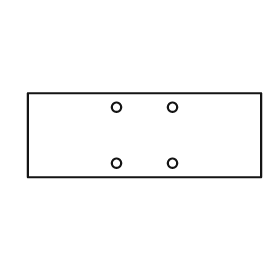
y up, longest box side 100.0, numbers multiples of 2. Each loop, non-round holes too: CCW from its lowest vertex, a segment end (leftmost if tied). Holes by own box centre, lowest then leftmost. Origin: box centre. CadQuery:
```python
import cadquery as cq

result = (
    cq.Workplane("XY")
    .moveTo(-50.0, -18.0)
    .lineTo(50.0, -18.0)
    .lineTo(50.0, 18.0)
    .lineTo(-50.0, 18.0)
    .close()
    .moveTo(-12.0, -12.0)
    .circle(2.0)
    .moveTo(12.0, -12.0)
    .circle(2.0)
    .moveTo(-12.0, 12.0)
    .circle(2.0)
    .moveTo(12.0, 12.0)
    .circle(2.0)
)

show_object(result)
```